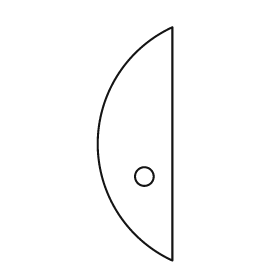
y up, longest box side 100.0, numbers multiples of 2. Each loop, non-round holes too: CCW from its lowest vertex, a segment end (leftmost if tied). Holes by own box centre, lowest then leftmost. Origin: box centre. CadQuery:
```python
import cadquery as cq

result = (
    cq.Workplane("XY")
    .moveTo(16.0, -50.0)
    .lineTo(16.0, 50.0)
    .threePointArc((-16.0, 0.0), (16.0, -50.0))
    .close()
    .moveTo(4.0, -14.0)
    .circle(4.0)
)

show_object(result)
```